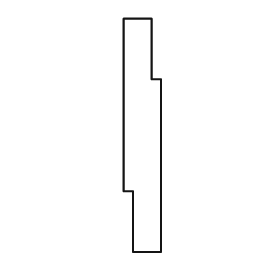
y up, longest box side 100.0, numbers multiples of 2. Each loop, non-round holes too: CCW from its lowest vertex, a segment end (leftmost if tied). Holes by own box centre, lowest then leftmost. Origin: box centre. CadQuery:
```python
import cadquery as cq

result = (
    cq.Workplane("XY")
    .moveTo(-4.0, -50.0)
    .lineTo(8.0, -50.0)
    .lineTo(8.0, 24.0)
    .lineTo(4.0, 24.0)
    .lineTo(4.0, 50.0)
    .lineTo(-8.0, 50.0)
    .lineTo(-8.0, -24.0)
    .lineTo(-4.0, -24.0)
    .close()
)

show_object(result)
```